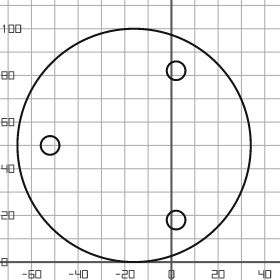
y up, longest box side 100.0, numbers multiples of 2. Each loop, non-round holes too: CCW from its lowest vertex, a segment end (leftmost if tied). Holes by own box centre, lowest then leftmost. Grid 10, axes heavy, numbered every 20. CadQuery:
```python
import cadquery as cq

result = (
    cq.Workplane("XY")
    .moveTo(-16.0, 50.0)
    .circle(50.0)
    .moveTo(2.0, 18.0)
    .circle(4.0)
    .moveTo(-52.0, 50.0)
    .circle(4.0)
    .moveTo(2.0, 82.0)
    .circle(4.0)
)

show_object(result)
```